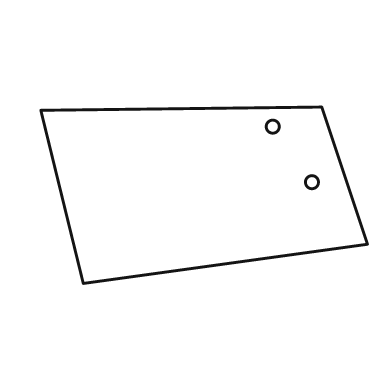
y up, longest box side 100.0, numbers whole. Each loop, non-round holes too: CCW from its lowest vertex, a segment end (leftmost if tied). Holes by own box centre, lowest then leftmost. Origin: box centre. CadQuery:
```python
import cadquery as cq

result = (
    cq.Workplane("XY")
    .moveTo(-37.0, -27.0)
    .lineTo(50.0, -15.0)
    .lineTo(36.0, 27.0)
    .lineTo(-50.0, 26.0)
    .close()
    .moveTo(33.0, 4.0)
    .circle(2.0)
    .moveTo(21.0, 21.0)
    .circle(2.0)
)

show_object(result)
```